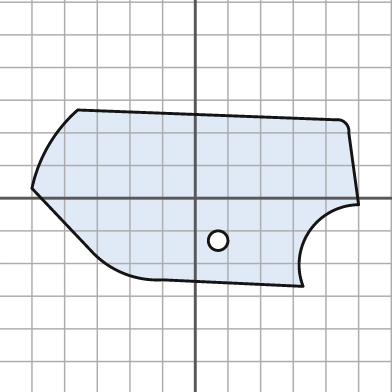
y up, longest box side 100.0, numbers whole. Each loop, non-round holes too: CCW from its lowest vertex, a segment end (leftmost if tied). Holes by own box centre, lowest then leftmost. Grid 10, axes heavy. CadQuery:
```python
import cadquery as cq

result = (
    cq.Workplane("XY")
    .moveTo(33.0, -27.0)
    .threePointArc((35.0, -10.0), (50.0, -2.0))
    .lineTo(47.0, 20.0)
    .threePointArc((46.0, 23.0), (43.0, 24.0))
    .lineTo(-36.0, 27.0)
    .threePointArc((-45.0, 16.0), (-50.0, 3.0))
    .lineTo(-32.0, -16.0)
    .threePointArc((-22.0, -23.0), (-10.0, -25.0))
    .close()
    .moveTo(7.0, -13.0)
    .circle(3.0)
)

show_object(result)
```